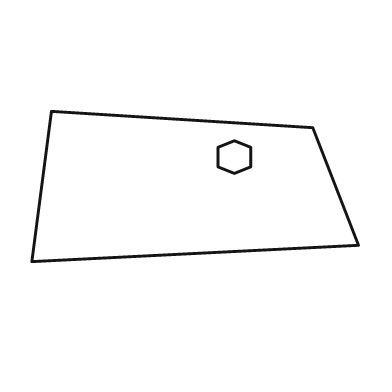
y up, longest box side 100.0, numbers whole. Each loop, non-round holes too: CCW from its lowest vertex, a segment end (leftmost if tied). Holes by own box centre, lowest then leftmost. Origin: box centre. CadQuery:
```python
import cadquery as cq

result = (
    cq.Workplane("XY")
    .moveTo(-50.0, -23.0)
    .lineTo(50.0, -18.0)
    .lineTo(36.0, 18.0)
    .lineTo(-44.0, 23.0)
    .close()
    .moveTo(12.0, 4.0)
    .lineTo(17.0, 6.0)
    .lineTo(17.0, 12.0)
    .lineTo(12.0, 14.0)
    .lineTo(7.0, 12.0)
    .lineTo(7.0, 6.0)
    .close()
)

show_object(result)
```